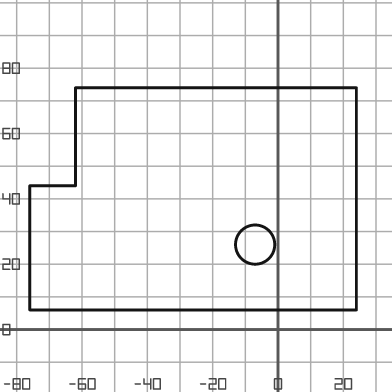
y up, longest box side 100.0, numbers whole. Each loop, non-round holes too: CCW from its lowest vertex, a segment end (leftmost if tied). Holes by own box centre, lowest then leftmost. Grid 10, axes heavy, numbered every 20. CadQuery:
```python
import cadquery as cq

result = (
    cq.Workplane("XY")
    .moveTo(-76.0, 6.0)
    .lineTo(24.0, 6.0)
    .lineTo(24.0, 74.0)
    .lineTo(-62.0, 74.0)
    .lineTo(-62.0, 44.0)
    .lineTo(-76.0, 44.0)
    .close()
    .moveTo(-7.0, 26.0)
    .circle(6.0)
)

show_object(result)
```